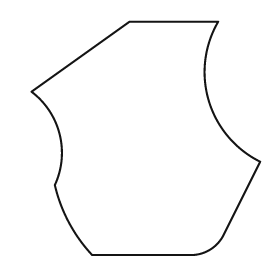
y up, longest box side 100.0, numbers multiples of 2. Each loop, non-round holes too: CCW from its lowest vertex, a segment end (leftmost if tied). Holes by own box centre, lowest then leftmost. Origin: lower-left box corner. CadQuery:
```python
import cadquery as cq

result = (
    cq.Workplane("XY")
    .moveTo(26.0, 0.0)
    .lineTo(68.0, 0.0)
    .threePointArc((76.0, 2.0), (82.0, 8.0))
    .lineTo(98.0, 40.0)
    .threePointArc((76.0, 66.0), (80.0, 100.0))
    .lineTo(42.0, 100.0)
    .lineTo(0.0, 70.0)
    .threePointArc((12.0, 52.0), (10.0, 30.0))
    .threePointArc((16.0, 14.0), (26.0, 0.0))
    .close()
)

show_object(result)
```